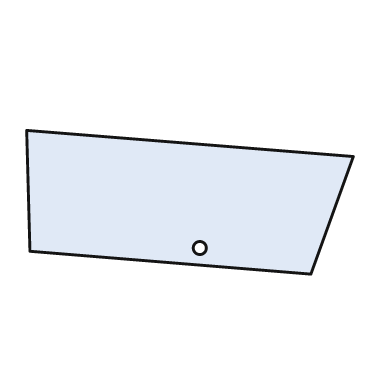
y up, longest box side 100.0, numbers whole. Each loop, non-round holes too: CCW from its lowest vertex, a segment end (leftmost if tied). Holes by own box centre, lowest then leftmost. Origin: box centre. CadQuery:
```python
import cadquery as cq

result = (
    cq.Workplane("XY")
    .moveTo(37.0, -22.0)
    .lineTo(50.0, 14.0)
    .lineTo(-50.0, 22.0)
    .lineTo(-49.0, -15.0)
    .close()
    .moveTo(3.0, -14.0)
    .circle(2.0)
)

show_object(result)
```